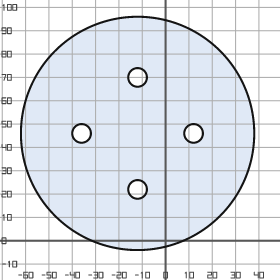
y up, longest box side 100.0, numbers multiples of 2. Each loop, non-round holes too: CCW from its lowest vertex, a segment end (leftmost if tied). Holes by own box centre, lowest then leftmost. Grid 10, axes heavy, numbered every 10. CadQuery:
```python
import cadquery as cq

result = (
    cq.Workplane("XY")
    .moveTo(-12.0, 46.0)
    .circle(50.0)
    .moveTo(-12.0, 22.0)
    .circle(4.0)
    .moveTo(-36.0, 46.0)
    .circle(4.0)
    .moveTo(12.0, 46.0)
    .circle(4.0)
    .moveTo(-12.0, 70.0)
    .circle(4.0)
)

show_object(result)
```